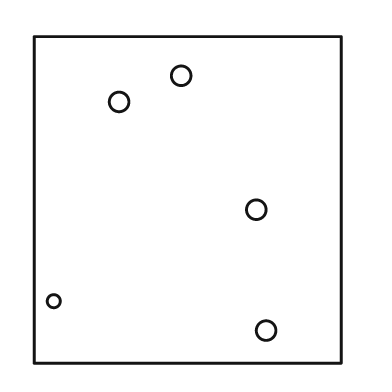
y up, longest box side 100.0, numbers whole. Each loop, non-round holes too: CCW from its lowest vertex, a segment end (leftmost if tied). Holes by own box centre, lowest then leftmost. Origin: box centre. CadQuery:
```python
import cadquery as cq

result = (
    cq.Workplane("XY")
    .moveTo(-47.0, -50.0)
    .lineTo(47.0, -50.0)
    .lineTo(47.0, 50.0)
    .lineTo(-47.0, 50.0)
    .close()
    .moveTo(24.0, -40.0)
    .circle(3.0)
    .moveTo(-41.0, -31.0)
    .circle(2.0)
    .moveTo(21.0, -3.0)
    .circle(3.0)
    .moveTo(-21.0, 30.0)
    .circle(3.0)
    .moveTo(-2.0, 38.0)
    .circle(3.0)
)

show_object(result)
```